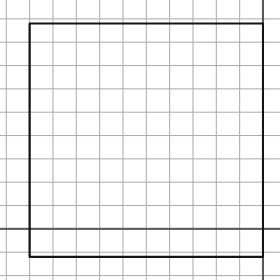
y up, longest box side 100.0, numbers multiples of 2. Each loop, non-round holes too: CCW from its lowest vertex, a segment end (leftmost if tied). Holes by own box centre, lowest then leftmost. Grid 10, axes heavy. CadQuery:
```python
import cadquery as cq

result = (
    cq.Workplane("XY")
    .moveTo(-100.0, -12.0)
    .lineTo(0.0, -12.0)
    .lineTo(0.0, 88.0)
    .lineTo(-100.0, 88.0)
    .close()
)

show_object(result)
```